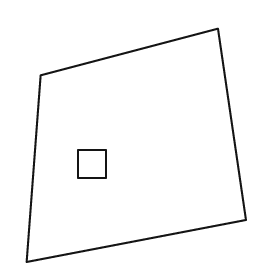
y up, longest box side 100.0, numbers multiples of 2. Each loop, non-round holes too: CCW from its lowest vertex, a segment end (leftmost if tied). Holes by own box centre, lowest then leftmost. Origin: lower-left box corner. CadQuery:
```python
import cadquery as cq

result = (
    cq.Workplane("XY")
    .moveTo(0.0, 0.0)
    .lineTo(94.0, 18.0)
    .lineTo(82.0, 100.0)
    .lineTo(6.0, 80.0)
    .close()
    .moveTo(22.0, 36.0)
    .lineTo(34.0, 36.0)
    .lineTo(34.0, 48.0)
    .lineTo(22.0, 48.0)
    .close()
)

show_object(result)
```